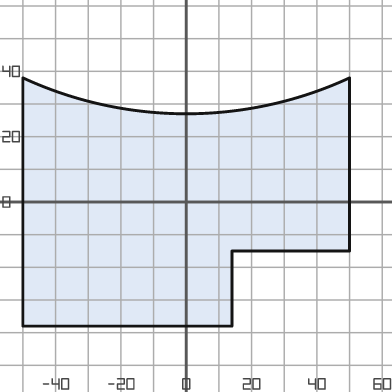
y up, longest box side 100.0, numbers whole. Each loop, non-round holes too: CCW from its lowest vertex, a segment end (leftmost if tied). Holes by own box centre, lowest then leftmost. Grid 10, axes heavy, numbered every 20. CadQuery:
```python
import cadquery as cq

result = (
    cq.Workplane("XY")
    .moveTo(-50.0, -38.0)
    .lineTo(14.0, -38.0)
    .lineTo(14.0, -15.0)
    .lineTo(50.0, -15.0)
    .lineTo(50.0, 38.0)
    .threePointArc((0.0, 27.0), (-50.0, 38.0))
    .close()
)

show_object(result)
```